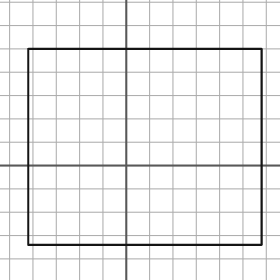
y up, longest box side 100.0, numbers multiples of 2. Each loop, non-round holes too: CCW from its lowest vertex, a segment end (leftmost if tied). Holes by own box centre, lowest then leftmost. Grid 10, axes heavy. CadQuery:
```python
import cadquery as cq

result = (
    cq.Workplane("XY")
    .moveTo(-42.0, -34.0)
    .lineTo(58.0, -34.0)
    .lineTo(58.0, 50.0)
    .lineTo(-42.0, 50.0)
    .close()
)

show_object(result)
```